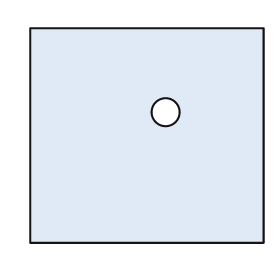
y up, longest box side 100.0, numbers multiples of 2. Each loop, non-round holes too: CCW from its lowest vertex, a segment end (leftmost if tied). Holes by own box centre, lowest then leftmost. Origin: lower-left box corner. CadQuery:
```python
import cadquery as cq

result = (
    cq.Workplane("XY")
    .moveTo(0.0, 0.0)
    .lineTo(100.0, 0.0)
    .lineTo(100.0, 92.0)
    .lineTo(0.0, 92.0)
    .close()
    .moveTo(58.0, 56.0)
    .circle(6.0)
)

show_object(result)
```